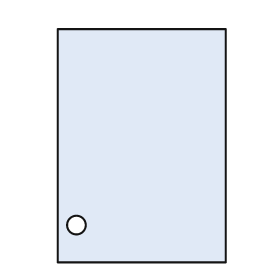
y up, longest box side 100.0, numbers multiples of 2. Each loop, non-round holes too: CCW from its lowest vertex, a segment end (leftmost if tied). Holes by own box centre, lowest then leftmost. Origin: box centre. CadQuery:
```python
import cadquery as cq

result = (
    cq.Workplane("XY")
    .moveTo(-36.0, -50.0)
    .lineTo(36.0, -50.0)
    .lineTo(36.0, 50.0)
    .lineTo(-36.0, 50.0)
    .close()
    .moveTo(-28.0, -34.0)
    .circle(4.0)
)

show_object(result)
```